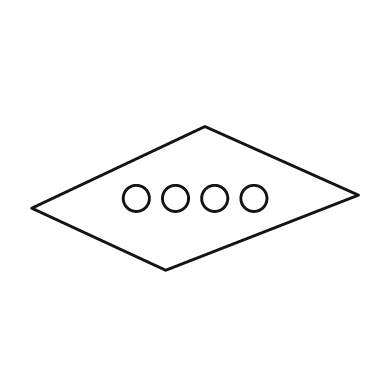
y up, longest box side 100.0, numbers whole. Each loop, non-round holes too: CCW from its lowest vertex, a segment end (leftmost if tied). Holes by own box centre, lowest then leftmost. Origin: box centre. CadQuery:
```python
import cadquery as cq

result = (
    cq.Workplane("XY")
    .moveTo(-9.0, -22.0)
    .lineTo(50.0, 1.0)
    .lineTo(3.0, 22.0)
    .lineTo(-50.0, -3.0)
    .close()
    .moveTo(-18.0, 0.0)
    .circle(4.0)
    .moveTo(-6.0, 0.0)
    .circle(4.0)
    .moveTo(6.0, 0.0)
    .circle(4.0)
    .moveTo(18.0, 0.0)
    .circle(4.0)
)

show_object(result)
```